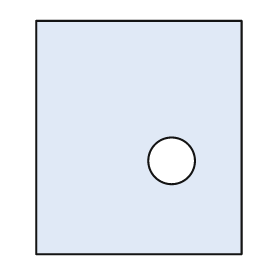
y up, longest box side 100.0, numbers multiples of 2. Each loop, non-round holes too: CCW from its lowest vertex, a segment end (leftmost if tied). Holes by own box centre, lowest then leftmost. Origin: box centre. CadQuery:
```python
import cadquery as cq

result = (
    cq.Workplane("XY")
    .moveTo(-44.0, -50.0)
    .lineTo(44.0, -50.0)
    .lineTo(44.0, 50.0)
    .lineTo(-44.0, 50.0)
    .close()
    .moveTo(14.0, -10.0)
    .circle(10.0)
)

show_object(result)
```